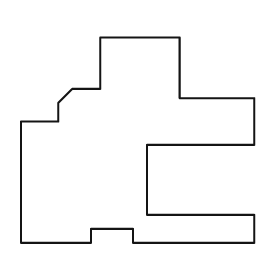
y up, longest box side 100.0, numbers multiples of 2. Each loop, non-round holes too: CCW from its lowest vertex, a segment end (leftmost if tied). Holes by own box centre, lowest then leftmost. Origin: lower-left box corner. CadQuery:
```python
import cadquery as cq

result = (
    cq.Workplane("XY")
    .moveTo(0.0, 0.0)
    .lineTo(30.0, 0.0)
    .lineTo(30.0, 6.0)
    .lineTo(48.0, 6.0)
    .lineTo(48.0, 0.0)
    .lineTo(100.0, 0.0)
    .lineTo(100.0, 12.0)
    .lineTo(54.0, 12.0)
    .lineTo(54.0, 42.0)
    .lineTo(100.0, 42.0)
    .lineTo(100.0, 62.0)
    .lineTo(68.0, 62.0)
    .lineTo(68.0, 88.0)
    .lineTo(34.0, 88.0)
    .lineTo(34.0, 66.0)
    .lineTo(22.0, 66.0)
    .lineTo(16.0, 60.0)
    .lineTo(16.0, 52.0)
    .lineTo(0.0, 52.0)
    .close()
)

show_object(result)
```